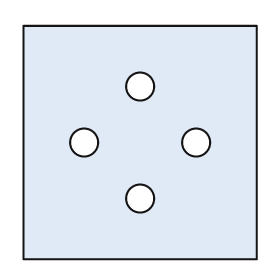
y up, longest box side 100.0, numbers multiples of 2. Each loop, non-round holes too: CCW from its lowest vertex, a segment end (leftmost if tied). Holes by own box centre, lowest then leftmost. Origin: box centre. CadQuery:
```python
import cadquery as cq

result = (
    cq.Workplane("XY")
    .moveTo(-50.0, -50.0)
    .lineTo(50.0, -50.0)
    .lineTo(50.0, 50.0)
    .lineTo(-50.0, 50.0)
    .close()
    .moveTo(0.0, -24.0)
    .circle(6.0)
    .moveTo(-24.0, 0.0)
    .circle(6.0)
    .moveTo(24.0, 0.0)
    .circle(6.0)
    .moveTo(0.0, 24.0)
    .circle(6.0)
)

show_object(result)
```